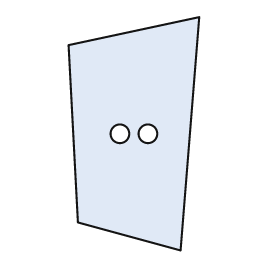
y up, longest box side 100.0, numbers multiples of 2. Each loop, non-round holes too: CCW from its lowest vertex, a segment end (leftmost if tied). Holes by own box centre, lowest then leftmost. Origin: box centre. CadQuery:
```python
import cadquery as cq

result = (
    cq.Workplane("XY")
    .moveTo(20.0, -50.0)
    .lineTo(28.0, 50.0)
    .lineTo(-28.0, 38.0)
    .lineTo(-24.0, -38.0)
    .close()
    .moveTo(-6.0, 0.0)
    .circle(4.0)
    .moveTo(6.0, 0.0)
    .circle(4.0)
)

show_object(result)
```